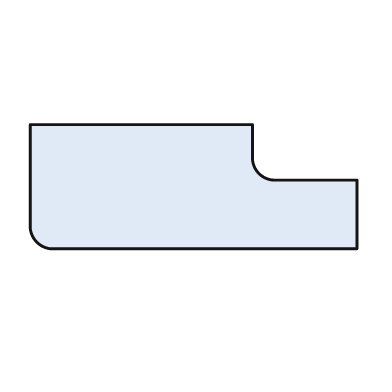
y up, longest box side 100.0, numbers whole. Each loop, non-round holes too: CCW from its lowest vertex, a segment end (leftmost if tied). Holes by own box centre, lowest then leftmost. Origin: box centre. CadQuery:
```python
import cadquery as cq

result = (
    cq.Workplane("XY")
    .moveTo(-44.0, -19.0)
    .lineTo(50.0, -19.0)
    .lineTo(50.0, 2.0)
    .lineTo(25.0, 2.0)
    .threePointArc((20.0, 4.0), (18.0, 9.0))
    .lineTo(18.0, 19.0)
    .lineTo(-50.0, 19.0)
    .lineTo(-50.0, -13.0)
    .threePointArc((-48.0, -17.0), (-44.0, -19.0))
    .close()
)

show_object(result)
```